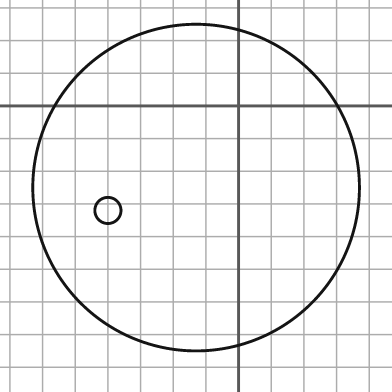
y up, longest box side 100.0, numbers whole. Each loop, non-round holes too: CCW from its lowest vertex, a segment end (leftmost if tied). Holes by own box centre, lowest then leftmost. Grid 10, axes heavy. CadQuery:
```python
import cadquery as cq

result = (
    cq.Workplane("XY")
    .moveTo(-13.0, -25.0)
    .circle(50.0)
    .moveTo(-40.0, -32.0)
    .circle(4.0)
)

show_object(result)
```